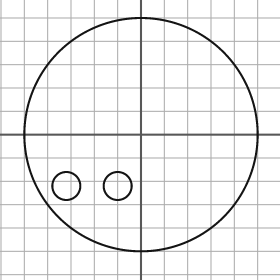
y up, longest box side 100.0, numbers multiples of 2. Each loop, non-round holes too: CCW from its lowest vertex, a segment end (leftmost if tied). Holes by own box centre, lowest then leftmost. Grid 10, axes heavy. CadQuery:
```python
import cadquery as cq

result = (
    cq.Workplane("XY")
    .moveTo(0.0, 0.0)
    .circle(50.0)
    .moveTo(-32.0, -22.0)
    .circle(6.0)
    .moveTo(-10.0, -22.0)
    .circle(6.0)
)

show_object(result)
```